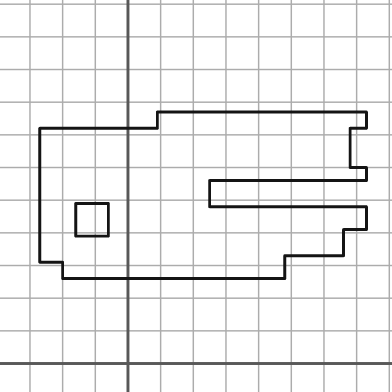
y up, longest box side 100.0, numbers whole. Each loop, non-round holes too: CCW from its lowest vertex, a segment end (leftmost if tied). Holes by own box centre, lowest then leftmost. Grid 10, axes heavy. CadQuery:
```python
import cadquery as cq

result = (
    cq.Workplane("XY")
    .moveTo(-20.0, 26.0)
    .lineTo(48.0, 26.0)
    .lineTo(48.0, 33.0)
    .lineTo(66.0, 33.0)
    .lineTo(66.0, 41.0)
    .lineTo(73.0, 41.0)
    .lineTo(73.0, 48.0)
    .lineTo(25.0, 48.0)
    .lineTo(25.0, 56.0)
    .lineTo(73.0, 56.0)
    .lineTo(73.0, 60.0)
    .lineTo(68.0, 60.0)
    .lineTo(68.0, 72.0)
    .lineTo(73.0, 72.0)
    .lineTo(73.0, 77.0)
    .lineTo(9.0, 77.0)
    .lineTo(9.0, 72.0)
    .lineTo(-27.0, 72.0)
    .lineTo(-27.0, 31.0)
    .lineTo(-20.0, 31.0)
    .close()
    .moveTo(-16.0, 39.0)
    .lineTo(-6.0, 39.0)
    .lineTo(-6.0, 49.0)
    .lineTo(-16.0, 49.0)
    .close()
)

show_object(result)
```